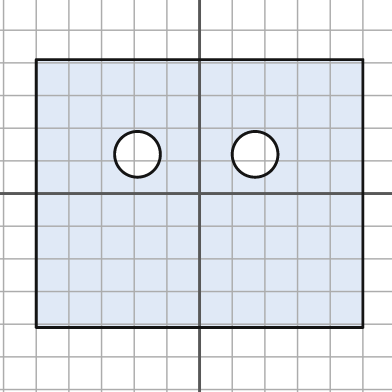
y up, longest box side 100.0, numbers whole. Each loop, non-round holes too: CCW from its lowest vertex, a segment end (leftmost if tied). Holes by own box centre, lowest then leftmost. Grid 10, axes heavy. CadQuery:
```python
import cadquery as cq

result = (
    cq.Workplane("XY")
    .moveTo(-50.0, -41.0)
    .lineTo(50.0, -41.0)
    .lineTo(50.0, 41.0)
    .lineTo(-50.0, 41.0)
    .close()
    .moveTo(-19.0, 12.0)
    .circle(7.0)
    .moveTo(17.0, 12.0)
    .circle(7.0)
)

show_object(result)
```